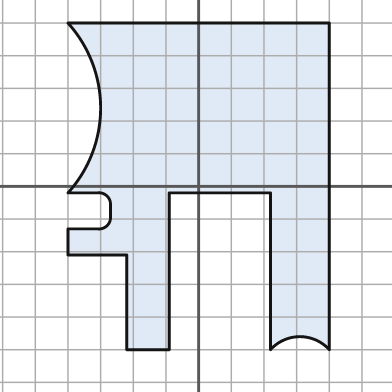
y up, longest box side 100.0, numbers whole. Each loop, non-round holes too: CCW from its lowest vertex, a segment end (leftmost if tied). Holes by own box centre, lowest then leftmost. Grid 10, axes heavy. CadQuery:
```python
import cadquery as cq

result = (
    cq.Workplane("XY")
    .moveTo(-22.0, -50.0)
    .lineTo(-9.0, -50.0)
    .lineTo(-9.0, -2.0)
    .lineTo(22.0, -2.0)
    .lineTo(22.0, -50.0)
    .threePointArc((31.0, -46.0), (40.0, -50.0))
    .lineTo(40.0, 50.0)
    .lineTo(-40.0, 50.0)
    .threePointArc((-30.0, 24.0), (-40.0, -2.0))
    .lineTo(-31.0, -2.0)
    .threePointArc((-28.0, -3.0), (-27.0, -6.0))
    .lineTo(-27.0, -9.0)
    .threePointArc((-28.0, -12.0), (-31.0, -13.0))
    .lineTo(-40.0, -13.0)
    .lineTo(-40.0, -21.0)
    .lineTo(-22.0, -21.0)
    .close()
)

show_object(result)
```